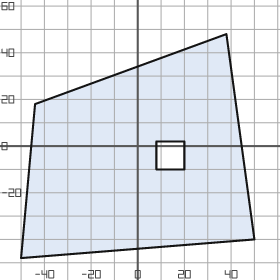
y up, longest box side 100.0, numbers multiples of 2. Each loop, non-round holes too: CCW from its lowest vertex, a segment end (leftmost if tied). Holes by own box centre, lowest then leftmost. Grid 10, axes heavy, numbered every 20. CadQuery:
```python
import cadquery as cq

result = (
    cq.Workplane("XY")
    .moveTo(-50.0, -48.0)
    .lineTo(50.0, -40.0)
    .lineTo(38.0, 48.0)
    .lineTo(-44.0, 18.0)
    .close()
    .moveTo(8.0, -10.0)
    .lineTo(20.0, -10.0)
    .lineTo(20.0, 2.0)
    .lineTo(8.0, 2.0)
    .close()
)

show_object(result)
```